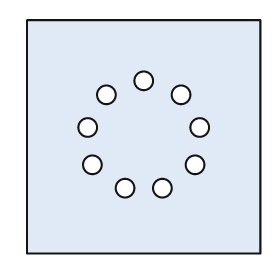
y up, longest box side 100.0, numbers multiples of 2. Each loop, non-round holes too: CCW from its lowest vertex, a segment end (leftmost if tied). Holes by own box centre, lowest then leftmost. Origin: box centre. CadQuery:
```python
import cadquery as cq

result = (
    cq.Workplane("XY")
    .moveTo(-50.0, -50.0)
    .lineTo(50.0, -50.0)
    .lineTo(50.0, 50.0)
    .lineTo(-50.0, 50.0)
    .close()
    .moveTo(-8.0, -22.0)
    .circle(4.0)
    .moveTo(8.0, -22.0)
    .circle(4.0)
    .moveTo(-22.0, -12.0)
    .circle(4.0)
    .moveTo(22.0, -12.0)
    .circle(4.0)
    .moveTo(-24.0, 4.0)
    .circle(4.0)
    .moveTo(24.0, 4.0)
    .circle(4.0)
    .moveTo(-16.0, 18.0)
    .circle(4.0)
    .moveTo(16.0, 18.0)
    .circle(4.0)
    .moveTo(0.0, 24.0)
    .circle(4.0)
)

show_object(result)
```